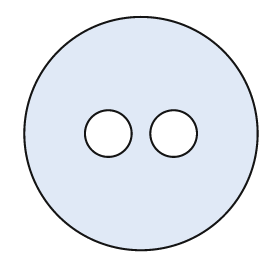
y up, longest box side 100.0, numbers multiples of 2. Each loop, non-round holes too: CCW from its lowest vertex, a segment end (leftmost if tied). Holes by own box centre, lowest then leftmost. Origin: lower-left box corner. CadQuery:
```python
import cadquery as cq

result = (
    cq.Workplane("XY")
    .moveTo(50.0, 50.0)
    .circle(50.0)
    .moveTo(36.0, 50.0)
    .circle(10.0)
    .moveTo(64.0, 50.0)
    .circle(10.0)
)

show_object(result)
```